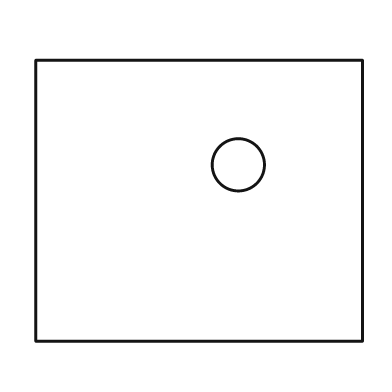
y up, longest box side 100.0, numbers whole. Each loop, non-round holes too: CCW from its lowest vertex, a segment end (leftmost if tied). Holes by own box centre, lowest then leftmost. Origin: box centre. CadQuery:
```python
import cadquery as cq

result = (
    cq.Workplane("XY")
    .moveTo(-50.0, -43.0)
    .lineTo(50.0, -43.0)
    .lineTo(50.0, 43.0)
    .lineTo(-50.0, 43.0)
    .close()
    .moveTo(12.0, 11.0)
    .circle(8.0)
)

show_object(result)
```